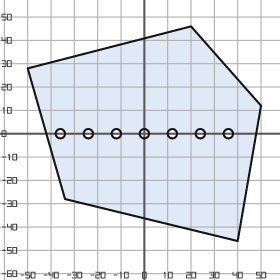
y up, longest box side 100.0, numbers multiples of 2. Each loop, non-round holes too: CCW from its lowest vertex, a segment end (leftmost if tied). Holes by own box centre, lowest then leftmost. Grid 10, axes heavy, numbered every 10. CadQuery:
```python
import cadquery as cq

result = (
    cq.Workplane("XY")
    .moveTo(40.0, -46.0)
    .lineTo(50.0, 12.0)
    .lineTo(20.0, 46.0)
    .lineTo(-50.0, 28.0)
    .lineTo(-34.0, -28.0)
    .close()
    .moveTo(-36.0, 0.0)
    .circle(2.0)
    .moveTo(-24.0, 0.0)
    .circle(2.0)
    .moveTo(-12.0, 0.0)
    .circle(2.0)
    .moveTo(0.0, 0.0)
    .circle(2.0)
    .moveTo(12.0, 0.0)
    .circle(2.0)
    .moveTo(24.0, 0.0)
    .circle(2.0)
    .moveTo(36.0, 0.0)
    .circle(2.0)
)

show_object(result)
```